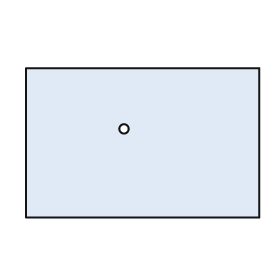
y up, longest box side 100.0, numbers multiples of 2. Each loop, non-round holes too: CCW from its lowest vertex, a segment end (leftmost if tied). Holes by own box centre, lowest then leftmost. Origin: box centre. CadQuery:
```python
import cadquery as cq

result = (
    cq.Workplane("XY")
    .moveTo(-50.0, -32.0)
    .lineTo(50.0, -32.0)
    .lineTo(50.0, 32.0)
    .lineTo(-50.0, 32.0)
    .close()
    .moveTo(-8.0, 6.0)
    .circle(2.0)
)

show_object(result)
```